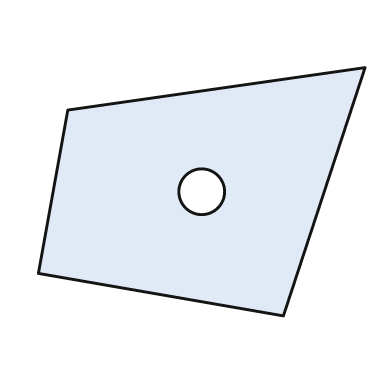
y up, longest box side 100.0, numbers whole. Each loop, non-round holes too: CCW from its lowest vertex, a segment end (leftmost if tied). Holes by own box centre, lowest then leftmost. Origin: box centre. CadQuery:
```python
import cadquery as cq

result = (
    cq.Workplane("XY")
    .moveTo(25.0, -38.0)
    .lineTo(50.0, 38.0)
    .lineTo(-41.0, 25.0)
    .lineTo(-50.0, -25.0)
    .close()
    .moveTo(0.0, 0.0)
    .circle(7.0)
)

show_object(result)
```